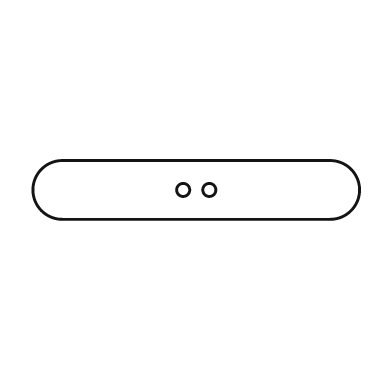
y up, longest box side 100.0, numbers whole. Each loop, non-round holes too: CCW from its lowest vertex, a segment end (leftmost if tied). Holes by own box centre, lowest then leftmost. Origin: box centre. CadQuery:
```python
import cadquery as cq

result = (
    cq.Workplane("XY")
    .moveTo(-41.0, -9.0)
    .lineTo(41.0, -9.0)
    .threePointArc((50.0, 0.0), (41.0, 9.0))
    .lineTo(-41.0, 9.0)
    .threePointArc((-50.0, 0.0), (-41.0, -9.0))
    .close()
    .moveTo(-4.0, 0.0)
    .circle(2.0)
    .moveTo(4.0, 0.0)
    .circle(2.0)
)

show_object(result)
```